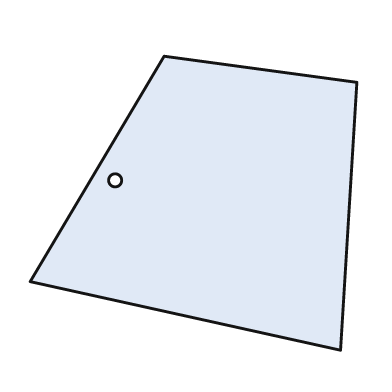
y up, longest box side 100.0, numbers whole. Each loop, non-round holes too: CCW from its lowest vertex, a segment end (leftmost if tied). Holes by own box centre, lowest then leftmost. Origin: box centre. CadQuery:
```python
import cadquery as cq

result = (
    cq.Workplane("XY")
    .moveTo(45.0, -45.0)
    .lineTo(50.0, 37.0)
    .lineTo(-9.0, 45.0)
    .lineTo(-50.0, -24.0)
    .close()
    .moveTo(-24.0, 7.0)
    .circle(2.0)
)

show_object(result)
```